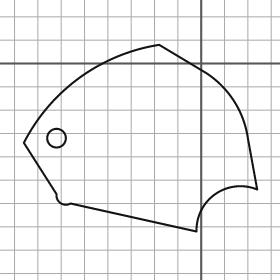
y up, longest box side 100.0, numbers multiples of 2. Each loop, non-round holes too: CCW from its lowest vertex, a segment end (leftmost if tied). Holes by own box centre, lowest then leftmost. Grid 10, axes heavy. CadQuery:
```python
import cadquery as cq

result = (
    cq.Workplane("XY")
    .moveTo(-2.0, -72.0)
    .threePointArc((6.0, -56.0), (24.0, -54.0))
    .lineTo(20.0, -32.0)
    .threePointArc((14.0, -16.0), (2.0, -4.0))
    .lineTo(-18.0, 8.0)
    .threePointArc((-52.0, -6.0), (-76.0, -34.0))
    .lineTo(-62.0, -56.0)
    .threePointArc((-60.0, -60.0), (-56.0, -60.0))
    .close()
    .moveTo(-62.0, -32.0)
    .circle(4.0)
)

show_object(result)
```